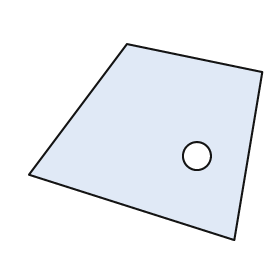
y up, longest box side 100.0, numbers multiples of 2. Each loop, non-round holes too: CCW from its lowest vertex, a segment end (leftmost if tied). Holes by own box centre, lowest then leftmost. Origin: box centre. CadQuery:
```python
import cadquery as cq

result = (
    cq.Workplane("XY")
    .moveTo(38.0, -42.0)
    .lineTo(50.0, 30.0)
    .lineTo(-8.0, 42.0)
    .lineTo(-50.0, -14.0)
    .close()
    .moveTo(22.0, -6.0)
    .circle(6.0)
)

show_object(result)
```